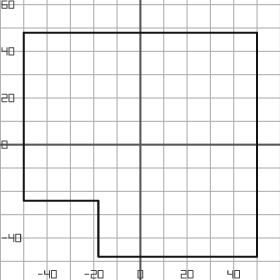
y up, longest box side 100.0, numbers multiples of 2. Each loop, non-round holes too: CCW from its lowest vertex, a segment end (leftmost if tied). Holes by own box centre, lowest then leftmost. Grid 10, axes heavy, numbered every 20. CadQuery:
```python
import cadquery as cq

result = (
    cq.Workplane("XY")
    .moveTo(-18.0, -48.0)
    .lineTo(50.0, -48.0)
    .lineTo(50.0, 48.0)
    .lineTo(-50.0, 48.0)
    .lineTo(-50.0, -24.0)
    .lineTo(-18.0, -24.0)
    .close()
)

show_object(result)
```